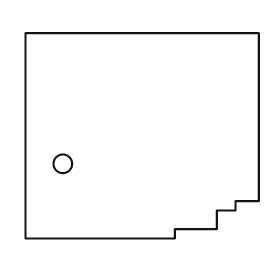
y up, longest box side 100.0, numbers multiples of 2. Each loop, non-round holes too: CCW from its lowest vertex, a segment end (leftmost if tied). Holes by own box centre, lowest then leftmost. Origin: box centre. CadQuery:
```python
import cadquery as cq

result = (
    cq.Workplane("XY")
    .moveTo(-50.0, -44.0)
    .lineTo(14.0, -44.0)
    .lineTo(14.0, -40.0)
    .lineTo(32.0, -40.0)
    .lineTo(32.0, -32.0)
    .lineTo(40.0, -32.0)
    .lineTo(40.0, -28.0)
    .lineTo(50.0, -28.0)
    .lineTo(50.0, 44.0)
    .lineTo(-50.0, 44.0)
    .close()
    .moveTo(-34.0, -12.0)
    .circle(4.0)
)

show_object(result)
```